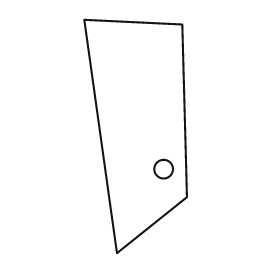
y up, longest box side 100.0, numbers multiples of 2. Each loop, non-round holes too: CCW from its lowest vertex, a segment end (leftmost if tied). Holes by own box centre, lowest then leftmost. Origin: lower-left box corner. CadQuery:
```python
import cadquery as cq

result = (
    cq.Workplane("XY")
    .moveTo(14.0, 0.0)
    .lineTo(44.0, 24.0)
    .lineTo(42.0, 98.0)
    .lineTo(0.0, 100.0)
    .close()
    .moveTo(34.0, 36.0)
    .circle(4.0)
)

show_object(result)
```